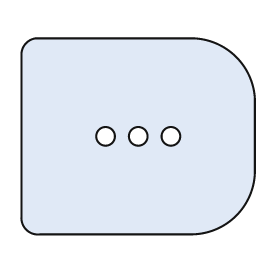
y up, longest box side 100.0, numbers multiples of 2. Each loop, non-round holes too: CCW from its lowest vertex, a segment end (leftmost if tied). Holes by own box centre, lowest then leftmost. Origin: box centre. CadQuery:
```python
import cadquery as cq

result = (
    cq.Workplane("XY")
    .moveTo(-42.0, -42.0)
    .lineTo(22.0, -42.0)
    .threePointArc((42.0, -34.0), (50.0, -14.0))
    .lineTo(50.0, 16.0)
    .threePointArc((42.0, 34.0), (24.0, 42.0))
    .lineTo(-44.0, 42.0)
    .threePointArc((-48.0, 40.0), (-50.0, 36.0))
    .lineTo(-50.0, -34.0)
    .threePointArc((-48.0, -40.0), (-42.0, -42.0))
    .close()
    .moveTo(-14.0, 0.0)
    .circle(4.0)
    .moveTo(0.0, 0.0)
    .circle(4.0)
    .moveTo(14.0, 0.0)
    .circle(4.0)
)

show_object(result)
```